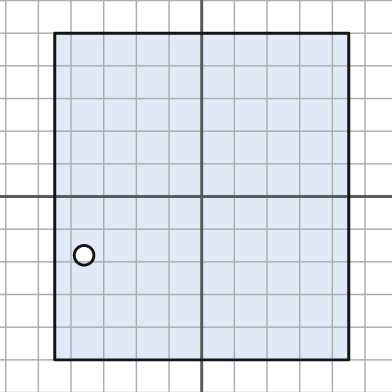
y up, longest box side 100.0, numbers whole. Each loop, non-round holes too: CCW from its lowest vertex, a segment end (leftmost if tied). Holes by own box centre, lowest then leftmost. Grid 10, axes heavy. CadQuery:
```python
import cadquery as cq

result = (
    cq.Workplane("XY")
    .moveTo(-45.0, -50.0)
    .lineTo(45.0, -50.0)
    .lineTo(45.0, 50.0)
    .lineTo(-45.0, 50.0)
    .close()
    .moveTo(-36.0, -18.0)
    .circle(3.0)
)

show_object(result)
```